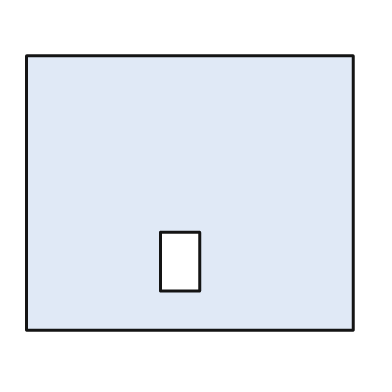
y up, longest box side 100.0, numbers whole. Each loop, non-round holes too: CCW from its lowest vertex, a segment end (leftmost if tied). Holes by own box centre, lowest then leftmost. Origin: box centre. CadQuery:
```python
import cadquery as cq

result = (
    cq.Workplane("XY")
    .moveTo(-50.0, -42.0)
    .lineTo(50.0, -42.0)
    .lineTo(50.0, 42.0)
    .lineTo(-50.0, 42.0)
    .close()
    .moveTo(-9.0, -30.0)
    .lineTo(3.0, -30.0)
    .lineTo(3.0, -12.0)
    .lineTo(-9.0, -12.0)
    .close()
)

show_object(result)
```